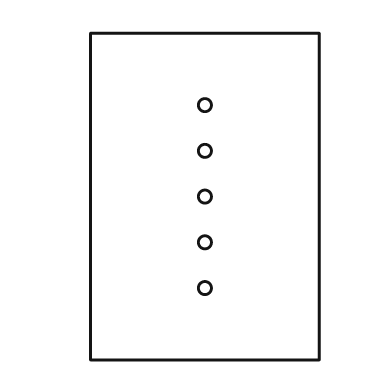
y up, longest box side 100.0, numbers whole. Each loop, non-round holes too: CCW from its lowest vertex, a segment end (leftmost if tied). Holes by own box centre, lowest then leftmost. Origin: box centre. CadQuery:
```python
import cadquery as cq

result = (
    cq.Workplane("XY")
    .moveTo(-35.0, -50.0)
    .lineTo(35.0, -50.0)
    .lineTo(35.0, 50.0)
    .lineTo(-35.0, 50.0)
    .close()
    .moveTo(0.0, -28.0)
    .circle(2.0)
    .moveTo(0.0, -14.0)
    .circle(2.0)
    .moveTo(0.0, 0.0)
    .circle(2.0)
    .moveTo(0.0, 14.0)
    .circle(2.0)
    .moveTo(0.0, 28.0)
    .circle(2.0)
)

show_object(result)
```